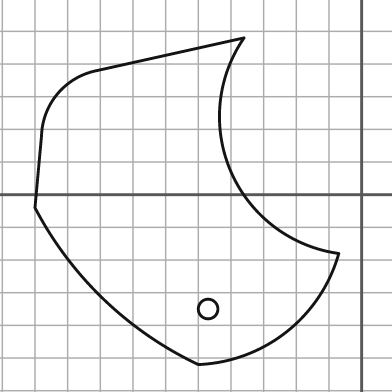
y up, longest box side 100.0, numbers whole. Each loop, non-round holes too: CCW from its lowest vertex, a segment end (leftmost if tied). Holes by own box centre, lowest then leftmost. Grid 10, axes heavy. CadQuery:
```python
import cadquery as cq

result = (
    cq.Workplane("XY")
    .moveTo(-50.0, -52.0)
    .threePointArc((-23.0, -42.0), (-7.0, -18.0))
    .threePointArc((-40.0, 7.0), (-36.0, 48.0))
    .lineTo(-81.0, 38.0)
    .threePointArc((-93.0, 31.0), (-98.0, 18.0))
    .lineTo(-100.0, -4.0)
    .threePointArc((-79.0, -32.0), (-50.0, -52.0))
    .close()
    .moveTo(-47.0, -35.0)
    .circle(3.0)
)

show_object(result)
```